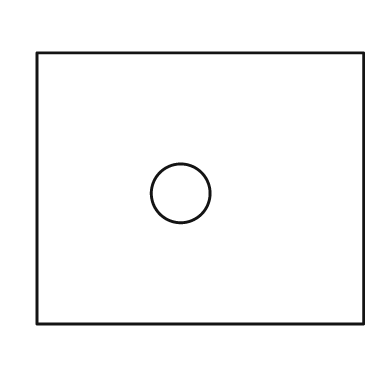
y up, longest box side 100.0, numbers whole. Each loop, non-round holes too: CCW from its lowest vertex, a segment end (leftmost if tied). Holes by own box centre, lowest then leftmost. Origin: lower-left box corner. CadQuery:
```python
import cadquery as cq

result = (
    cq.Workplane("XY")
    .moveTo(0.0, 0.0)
    .lineTo(100.0, 0.0)
    .lineTo(100.0, 83.0)
    .lineTo(0.0, 83.0)
    .close()
    .moveTo(44.0, 40.0)
    .circle(9.0)
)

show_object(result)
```